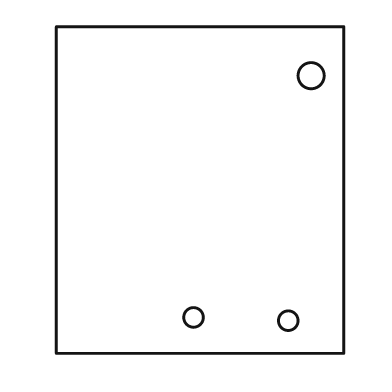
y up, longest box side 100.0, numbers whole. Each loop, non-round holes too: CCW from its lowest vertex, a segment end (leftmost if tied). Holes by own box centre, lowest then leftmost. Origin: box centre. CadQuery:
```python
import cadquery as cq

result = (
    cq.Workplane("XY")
    .moveTo(-44.0, -50.0)
    .lineTo(44.0, -50.0)
    .lineTo(44.0, 50.0)
    .lineTo(-44.0, 50.0)
    .close()
    .moveTo(27.0, -40.0)
    .circle(3.0)
    .moveTo(-2.0, -39.0)
    .circle(3.0)
    .moveTo(34.0, 35.0)
    .circle(4.0)
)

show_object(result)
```